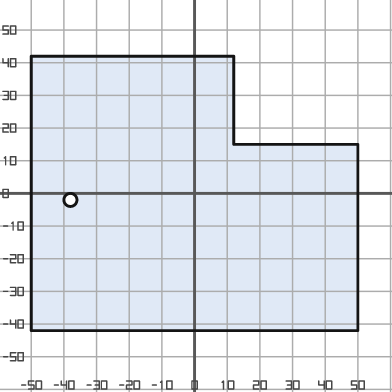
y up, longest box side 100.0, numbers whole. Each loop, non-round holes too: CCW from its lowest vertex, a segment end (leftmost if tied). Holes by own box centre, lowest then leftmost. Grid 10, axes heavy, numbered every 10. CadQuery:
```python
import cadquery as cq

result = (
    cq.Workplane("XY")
    .moveTo(-50.0, -42.0)
    .lineTo(50.0, -42.0)
    .lineTo(50.0, 15.0)
    .lineTo(12.0, 15.0)
    .lineTo(12.0, 42.0)
    .lineTo(-50.0, 42.0)
    .close()
    .moveTo(-38.0, -2.0)
    .circle(2.0)
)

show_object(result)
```